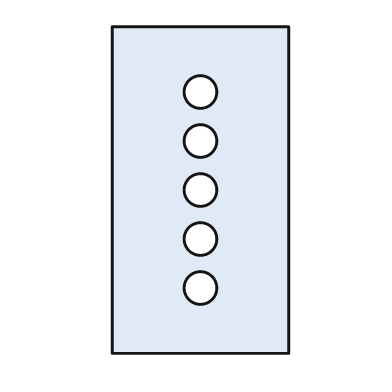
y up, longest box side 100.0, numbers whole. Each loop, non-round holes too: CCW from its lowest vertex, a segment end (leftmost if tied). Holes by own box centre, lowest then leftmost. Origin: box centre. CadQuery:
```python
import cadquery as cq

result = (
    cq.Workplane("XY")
    .moveTo(-27.0, -50.0)
    .lineTo(27.0, -50.0)
    .lineTo(27.0, 50.0)
    .lineTo(-27.0, 50.0)
    .close()
    .moveTo(0.0, -30.0)
    .circle(5.0)
    .moveTo(0.0, -15.0)
    .circle(5.0)
    .moveTo(0.0, 0.0)
    .circle(5.0)
    .moveTo(0.0, 15.0)
    .circle(5.0)
    .moveTo(0.0, 30.0)
    .circle(5.0)
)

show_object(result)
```